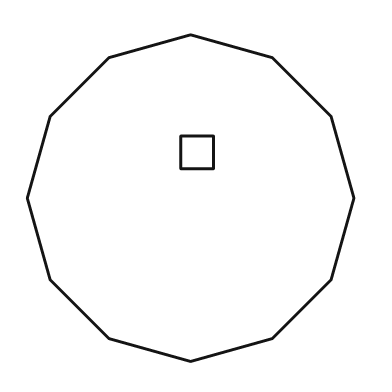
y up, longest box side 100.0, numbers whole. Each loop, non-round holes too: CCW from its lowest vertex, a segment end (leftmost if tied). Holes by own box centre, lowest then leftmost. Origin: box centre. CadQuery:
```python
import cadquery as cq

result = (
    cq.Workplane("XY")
    .moveTo(0.0, -50.0)
    .lineTo(25.0, -43.0)
    .lineTo(43.0, -25.0)
    .lineTo(50.0, 0.0)
    .lineTo(43.0, 25.0)
    .lineTo(25.0, 43.0)
    .lineTo(0.0, 50.0)
    .lineTo(-25.0, 43.0)
    .lineTo(-43.0, 25.0)
    .lineTo(-50.0, 0.0)
    .lineTo(-43.0, -25.0)
    .lineTo(-25.0, -43.0)
    .close()
    .moveTo(-3.0, 9.0)
    .lineTo(7.0, 9.0)
    .lineTo(7.0, 19.0)
    .lineTo(-3.0, 19.0)
    .close()
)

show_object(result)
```